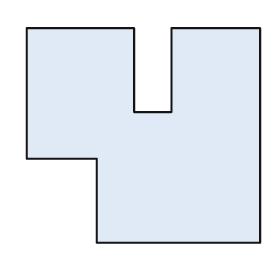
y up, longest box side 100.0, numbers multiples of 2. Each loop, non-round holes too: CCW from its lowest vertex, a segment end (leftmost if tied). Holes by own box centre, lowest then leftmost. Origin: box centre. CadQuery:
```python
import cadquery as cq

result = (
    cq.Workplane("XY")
    .moveTo(-20.0, -46.0)
    .lineTo(50.0, -46.0)
    .lineTo(50.0, 46.0)
    .lineTo(12.0, 46.0)
    .lineTo(12.0, 10.0)
    .lineTo(-4.0, 10.0)
    .lineTo(-4.0, 46.0)
    .lineTo(-50.0, 46.0)
    .lineTo(-50.0, -10.0)
    .lineTo(-20.0, -10.0)
    .close()
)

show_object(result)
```